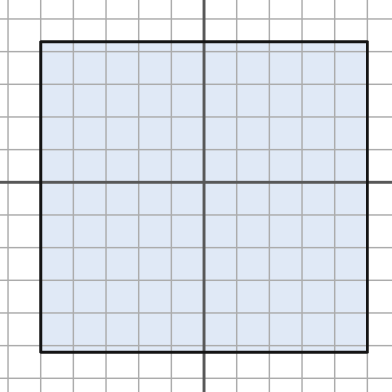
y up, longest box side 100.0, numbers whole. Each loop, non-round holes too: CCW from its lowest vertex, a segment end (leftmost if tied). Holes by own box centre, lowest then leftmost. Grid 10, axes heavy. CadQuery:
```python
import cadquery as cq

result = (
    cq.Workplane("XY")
    .moveTo(-50.0, -52.0)
    .lineTo(50.0, -52.0)
    .lineTo(50.0, 43.0)
    .lineTo(-50.0, 43.0)
    .close()
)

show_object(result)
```